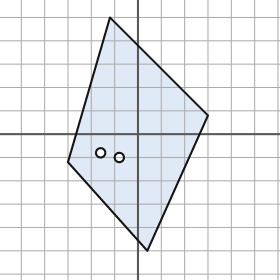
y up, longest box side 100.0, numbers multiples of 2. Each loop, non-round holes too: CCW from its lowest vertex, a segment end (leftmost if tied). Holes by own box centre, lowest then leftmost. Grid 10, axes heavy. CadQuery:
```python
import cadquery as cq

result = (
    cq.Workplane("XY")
    .moveTo(4.0, -50.0)
    .lineTo(30.0, 8.0)
    .lineTo(-12.0, 50.0)
    .lineTo(-30.0, -12.0)
    .close()
    .moveTo(-8.0, -10.0)
    .circle(2.0)
    .moveTo(-16.0, -8.0)
    .circle(2.0)
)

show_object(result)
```